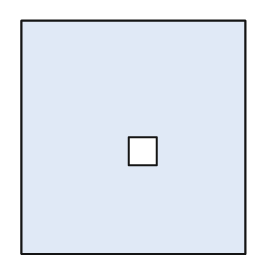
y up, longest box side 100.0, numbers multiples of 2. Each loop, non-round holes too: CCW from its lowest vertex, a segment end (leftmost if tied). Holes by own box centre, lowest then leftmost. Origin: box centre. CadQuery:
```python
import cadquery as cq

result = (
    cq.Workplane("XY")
    .moveTo(-48.0, -50.0)
    .lineTo(48.0, -50.0)
    .lineTo(48.0, 50.0)
    .lineTo(-48.0, 50.0)
    .close()
    .moveTo(-2.0, -12.0)
    .lineTo(10.0, -12.0)
    .lineTo(10.0, 0.0)
    .lineTo(-2.0, 0.0)
    .close()
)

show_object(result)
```